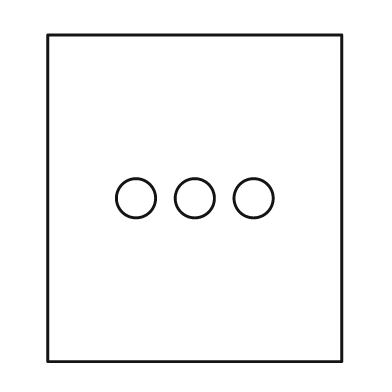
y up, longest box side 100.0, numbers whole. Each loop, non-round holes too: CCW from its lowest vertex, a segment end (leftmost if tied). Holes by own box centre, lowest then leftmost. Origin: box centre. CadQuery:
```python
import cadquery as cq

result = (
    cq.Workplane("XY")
    .moveTo(-45.0, -50.0)
    .lineTo(45.0, -50.0)
    .lineTo(45.0, 50.0)
    .lineTo(-45.0, 50.0)
    .close()
    .moveTo(-18.0, 0.0)
    .circle(6.0)
    .moveTo(0.0, 0.0)
    .circle(6.0)
    .moveTo(18.0, 0.0)
    .circle(6.0)
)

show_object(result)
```